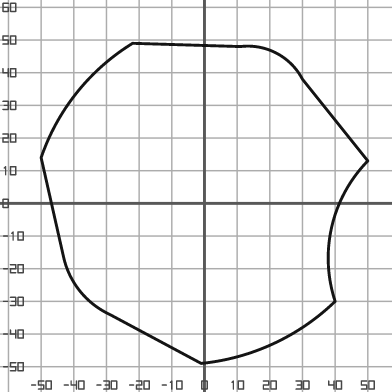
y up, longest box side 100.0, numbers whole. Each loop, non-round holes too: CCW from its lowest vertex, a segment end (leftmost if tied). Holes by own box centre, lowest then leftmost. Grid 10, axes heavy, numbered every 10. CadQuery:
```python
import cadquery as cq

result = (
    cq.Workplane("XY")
    .moveTo(-1.0, -49.0)
    .threePointArc((21.0, -43.0), (40.0, -30.0))
    .threePointArc((39.0, -7.0), (50.0, 13.0))
    .lineTo(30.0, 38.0)
    .threePointArc((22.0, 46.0), (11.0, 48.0))
    .lineTo(-22.0, 49.0)
    .threePointArc((-39.0, 34.0), (-50.0, 14.0))
    .lineTo(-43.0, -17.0)
    .threePointArc((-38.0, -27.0), (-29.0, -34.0))
    .close()
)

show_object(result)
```